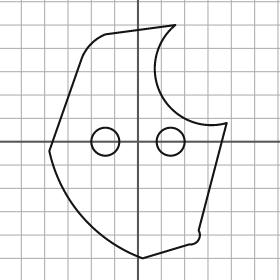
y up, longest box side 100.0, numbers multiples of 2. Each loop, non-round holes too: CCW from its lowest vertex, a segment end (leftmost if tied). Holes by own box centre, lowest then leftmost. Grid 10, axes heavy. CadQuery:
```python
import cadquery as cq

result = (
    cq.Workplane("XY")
    .moveTo(2.0, -50.0)
    .lineTo(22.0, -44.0)
    .threePointArc((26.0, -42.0), (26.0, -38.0))
    .lineTo(38.0, 8.0)
    .threePointArc((10.0, 20.0), (16.0, 50.0))
    .lineTo(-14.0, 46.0)
    .threePointArc((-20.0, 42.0), (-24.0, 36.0))
    .lineTo(-38.0, -4.0)
    .threePointArc((-24.0, -32.0), (2.0, -50.0))
    .close()
    .moveTo(-14.0, 0.0)
    .circle(6.0)
    .moveTo(14.0, 0.0)
    .circle(6.0)
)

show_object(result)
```